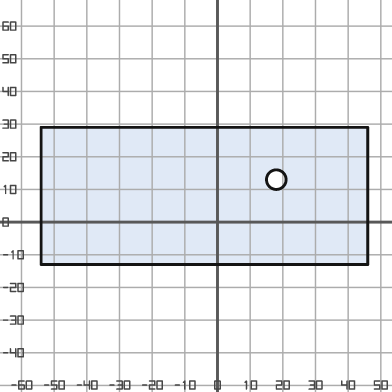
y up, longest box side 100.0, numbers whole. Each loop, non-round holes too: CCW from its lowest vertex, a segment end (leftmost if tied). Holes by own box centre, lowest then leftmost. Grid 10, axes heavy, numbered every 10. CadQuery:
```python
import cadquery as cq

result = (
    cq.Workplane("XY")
    .moveTo(-54.0, -13.0)
    .lineTo(46.0, -13.0)
    .lineTo(46.0, 29.0)
    .lineTo(-54.0, 29.0)
    .close()
    .moveTo(18.0, 13.0)
    .circle(3.0)
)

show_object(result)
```